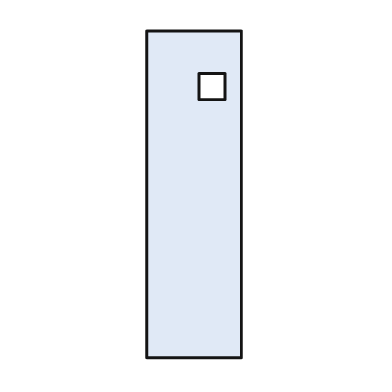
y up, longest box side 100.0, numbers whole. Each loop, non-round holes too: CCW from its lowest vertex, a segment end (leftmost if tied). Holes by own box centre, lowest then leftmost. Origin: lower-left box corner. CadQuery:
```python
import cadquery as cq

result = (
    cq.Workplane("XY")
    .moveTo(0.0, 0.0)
    .lineTo(29.0, 0.0)
    .lineTo(29.0, 100.0)
    .lineTo(0.0, 100.0)
    .close()
    .moveTo(16.0, 79.0)
    .lineTo(24.0, 79.0)
    .lineTo(24.0, 87.0)
    .lineTo(16.0, 87.0)
    .close()
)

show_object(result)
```